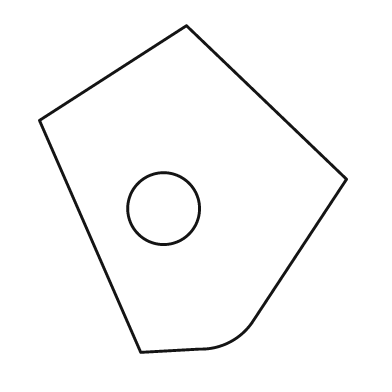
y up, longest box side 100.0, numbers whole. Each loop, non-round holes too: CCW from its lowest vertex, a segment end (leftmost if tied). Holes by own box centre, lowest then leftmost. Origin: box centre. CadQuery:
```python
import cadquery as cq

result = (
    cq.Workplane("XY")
    .moveTo(-16.0, -50.0)
    .lineTo(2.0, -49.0)
    .threePointArc((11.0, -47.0), (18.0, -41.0))
    .lineTo(47.0, 3.0)
    .lineTo(-2.0, 50.0)
    .lineTo(-47.0, 21.0)
    .close()
    .moveTo(-9.0, -6.0)
    .circle(11.0)
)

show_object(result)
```